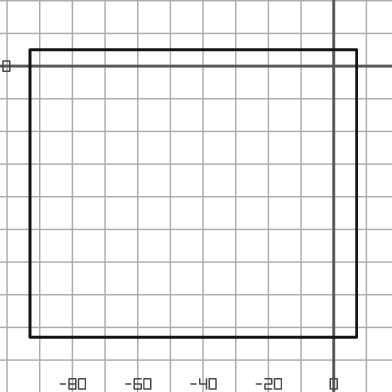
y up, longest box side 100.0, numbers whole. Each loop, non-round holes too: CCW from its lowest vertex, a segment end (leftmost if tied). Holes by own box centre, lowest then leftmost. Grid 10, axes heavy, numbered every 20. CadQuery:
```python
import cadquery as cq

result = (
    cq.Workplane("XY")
    .moveTo(-93.0, -83.0)
    .lineTo(7.0, -83.0)
    .lineTo(7.0, 5.0)
    .lineTo(-93.0, 5.0)
    .close()
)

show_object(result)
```